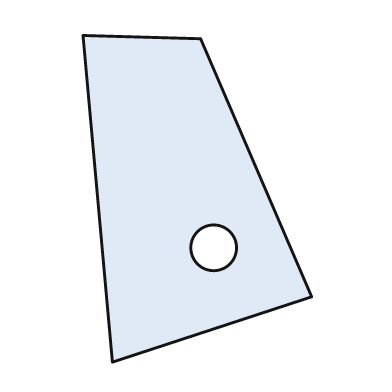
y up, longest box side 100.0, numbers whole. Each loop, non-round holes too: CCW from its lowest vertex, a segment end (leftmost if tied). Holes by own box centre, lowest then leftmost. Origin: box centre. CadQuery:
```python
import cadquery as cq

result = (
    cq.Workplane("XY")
    .moveTo(-26.0, -50.0)
    .lineTo(35.0, -30.0)
    .lineTo(1.0, 49.0)
    .lineTo(-35.0, 50.0)
    .close()
    .moveTo(5.0, -15.0)
    .circle(7.0)
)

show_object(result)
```